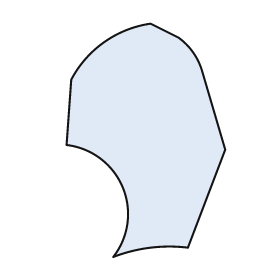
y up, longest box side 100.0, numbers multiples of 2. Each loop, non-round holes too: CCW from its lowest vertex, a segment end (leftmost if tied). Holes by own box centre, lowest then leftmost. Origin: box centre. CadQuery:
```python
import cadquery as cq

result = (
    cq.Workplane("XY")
    .moveTo(-14.0, -50.0)
    .threePointArc((2.0, -46.0), (18.0, -46.0))
    .lineTo(34.0, -4.0)
    .lineTo(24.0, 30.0)
    .threePointArc((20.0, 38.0), (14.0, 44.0))
    .lineTo(2.0, 50.0)
    .threePointArc((-18.0, 42.0), (-32.0, 26.0))
    .lineTo(-34.0, -2.0)
    .threePointArc((-10.0, -20.0), (-14.0, -50.0))
    .close()
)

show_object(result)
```